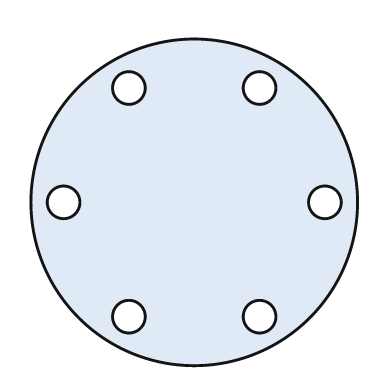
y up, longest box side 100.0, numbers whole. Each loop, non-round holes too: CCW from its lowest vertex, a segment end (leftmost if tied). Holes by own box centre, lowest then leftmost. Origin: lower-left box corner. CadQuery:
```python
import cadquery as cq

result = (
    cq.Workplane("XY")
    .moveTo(50.0, 50.0)
    .circle(50.0)
    .moveTo(30.0, 15.0)
    .circle(5.0)
    .moveTo(70.0, 15.0)
    .circle(5.0)
    .moveTo(10.0, 50.0)
    .circle(5.0)
    .moveTo(90.0, 50.0)
    .circle(5.0)
    .moveTo(30.0, 85.0)
    .circle(5.0)
    .moveTo(70.0, 85.0)
    .circle(5.0)
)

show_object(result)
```